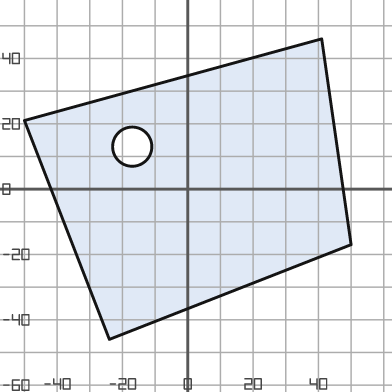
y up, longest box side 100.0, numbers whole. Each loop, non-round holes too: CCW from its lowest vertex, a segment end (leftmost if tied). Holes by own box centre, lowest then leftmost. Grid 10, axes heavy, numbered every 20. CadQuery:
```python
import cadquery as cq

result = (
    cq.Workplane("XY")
    .moveTo(-24.0, -46.0)
    .lineTo(50.0, -17.0)
    .lineTo(41.0, 46.0)
    .lineTo(-50.0, 21.0)
    .close()
    .moveTo(-17.0, 13.0)
    .circle(6.0)
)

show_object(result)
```